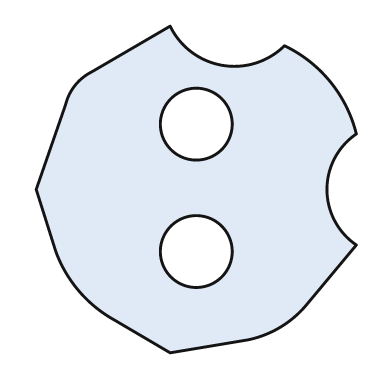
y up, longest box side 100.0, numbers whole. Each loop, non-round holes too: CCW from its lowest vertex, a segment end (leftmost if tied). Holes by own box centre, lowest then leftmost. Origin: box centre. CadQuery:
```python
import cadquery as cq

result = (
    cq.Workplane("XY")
    .moveTo(-8.0, -50.0)
    .lineTo(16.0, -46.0)
    .threePointArc((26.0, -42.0), (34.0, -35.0))
    .lineTo(49.0, -17.0)
    .threePointArc((40.0, 0.0), (49.0, 17.0))
    .threePointArc((41.0, 33.0), (27.0, 44.0))
    .threePointArc((8.0, 38.0), (-8.0, 50.0))
    .lineTo(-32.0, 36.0)
    .threePointArc((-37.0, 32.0), (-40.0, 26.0))
    .lineTo(-49.0, 0.0)
    .lineTo(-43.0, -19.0)
    .threePointArc((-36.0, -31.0), (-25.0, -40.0))
    .close()
    .moveTo(0.0, -19.0)
    .circle(11.0)
    .moveTo(0.0, 20.0)
    .circle(11.0)
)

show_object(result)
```